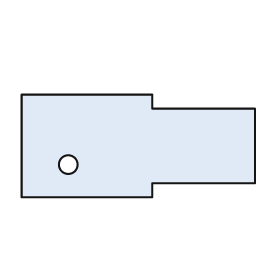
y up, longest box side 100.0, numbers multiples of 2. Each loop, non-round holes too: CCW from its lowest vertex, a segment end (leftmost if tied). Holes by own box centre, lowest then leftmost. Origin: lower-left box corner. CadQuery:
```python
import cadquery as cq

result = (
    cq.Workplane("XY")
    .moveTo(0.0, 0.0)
    .lineTo(56.0, 0.0)
    .lineTo(56.0, 6.0)
    .lineTo(100.0, 6.0)
    .lineTo(100.0, 38.0)
    .lineTo(56.0, 38.0)
    .lineTo(56.0, 44.0)
    .lineTo(0.0, 44.0)
    .close()
    .moveTo(20.0, 14.0)
    .circle(4.0)
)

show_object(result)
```